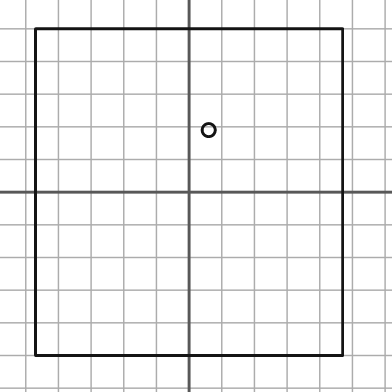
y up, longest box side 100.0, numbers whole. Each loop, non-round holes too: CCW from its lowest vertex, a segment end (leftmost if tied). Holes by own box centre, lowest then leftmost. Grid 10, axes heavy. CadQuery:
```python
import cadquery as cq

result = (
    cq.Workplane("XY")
    .moveTo(-47.0, -50.0)
    .lineTo(47.0, -50.0)
    .lineTo(47.0, 50.0)
    .lineTo(-47.0, 50.0)
    .close()
    .moveTo(6.0, 19.0)
    .circle(2.0)
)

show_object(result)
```